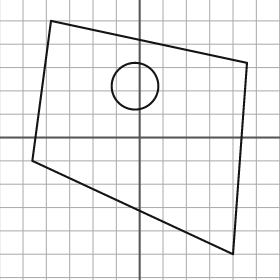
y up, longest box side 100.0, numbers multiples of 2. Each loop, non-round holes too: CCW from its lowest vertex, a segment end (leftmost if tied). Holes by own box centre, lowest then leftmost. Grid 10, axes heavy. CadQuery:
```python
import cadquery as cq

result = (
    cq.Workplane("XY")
    .moveTo(40.0, -50.0)
    .lineTo(46.0, 32.0)
    .lineTo(-38.0, 50.0)
    .lineTo(-46.0, -10.0)
    .close()
    .moveTo(-2.0, 22.0)
    .circle(10.0)
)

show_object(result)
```